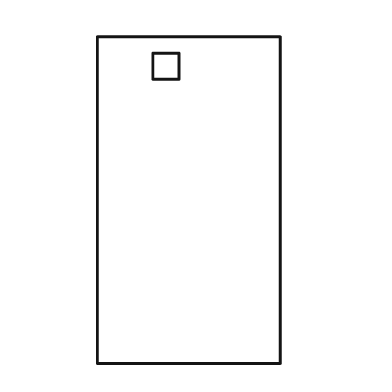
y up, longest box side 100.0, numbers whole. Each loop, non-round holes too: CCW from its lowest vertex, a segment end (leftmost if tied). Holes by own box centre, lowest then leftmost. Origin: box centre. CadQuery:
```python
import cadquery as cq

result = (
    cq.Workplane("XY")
    .moveTo(-28.0, -50.0)
    .lineTo(28.0, -50.0)
    .lineTo(28.0, 50.0)
    .lineTo(-28.0, 50.0)
    .close()
    .moveTo(-11.0, 37.0)
    .lineTo(-3.0, 37.0)
    .lineTo(-3.0, 45.0)
    .lineTo(-11.0, 45.0)
    .close()
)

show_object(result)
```